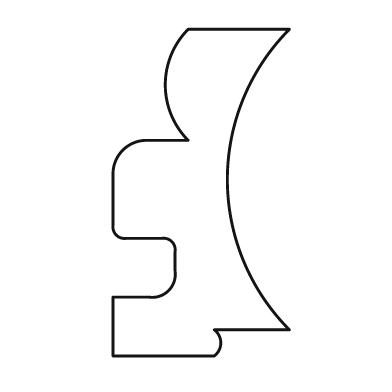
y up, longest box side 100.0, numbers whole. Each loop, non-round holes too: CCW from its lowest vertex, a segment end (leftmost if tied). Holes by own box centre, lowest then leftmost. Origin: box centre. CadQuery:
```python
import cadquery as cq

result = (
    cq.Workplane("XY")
    .moveTo(-27.0, -50.0)
    .lineTo(4.0, -50.0)
    .threePointArc((6.0, -46.0), (4.0, -42.0))
    .lineTo(27.0, -42.0)
    .threePointArc((8.0, 4.0), (27.0, 50.0))
    .lineTo(-4.0, 50.0)
    .threePointArc((-11.0, 33.0), (-4.0, 16.0))
    .lineTo(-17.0, 16.0)
    .threePointArc((-24.0, 13.0), (-27.0, 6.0))
    .lineTo(-27.0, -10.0)
    .threePointArc((-26.0, -13.0), (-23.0, -14.0))
    .lineTo(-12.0, -14.0)
    .threePointArc((-9.0, -15.0), (-8.0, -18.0))
    .lineTo(-8.0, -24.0)
    .threePointArc((-10.0, -30.0), (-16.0, -32.0))
    .lineTo(-27.0, -32.0)
    .close()
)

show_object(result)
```